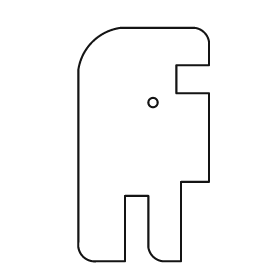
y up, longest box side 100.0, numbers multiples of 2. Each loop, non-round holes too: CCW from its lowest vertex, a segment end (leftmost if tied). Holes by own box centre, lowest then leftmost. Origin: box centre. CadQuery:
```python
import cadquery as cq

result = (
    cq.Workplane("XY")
    .moveTo(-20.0, -50.0)
    .lineTo(-8.0, -50.0)
    .lineTo(-8.0, -22.0)
    .lineTo(2.0, -22.0)
    .lineTo(2.0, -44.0)
    .threePointArc((4.0, -48.0), (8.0, -50.0))
    .lineTo(16.0, -50.0)
    .lineTo(16.0, -16.0)
    .lineTo(28.0, -16.0)
    .lineTo(28.0, 22.0)
    .lineTo(14.0, 22.0)
    .lineTo(14.0, 34.0)
    .lineTo(28.0, 34.0)
    .lineTo(28.0, 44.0)
    .threePointArc((26.0, 48.0), (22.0, 50.0))
    .lineTo(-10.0, 50.0)
    .threePointArc((-22.0, 44.0), (-28.0, 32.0))
    .lineTo(-28.0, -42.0)
    .threePointArc((-26.0, -48.0), (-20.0, -50.0))
    .close()
    .moveTo(4.0, 18.0)
    .circle(2.0)
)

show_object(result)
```